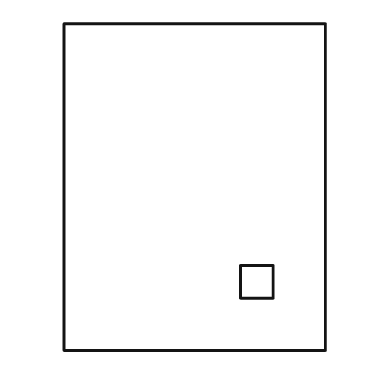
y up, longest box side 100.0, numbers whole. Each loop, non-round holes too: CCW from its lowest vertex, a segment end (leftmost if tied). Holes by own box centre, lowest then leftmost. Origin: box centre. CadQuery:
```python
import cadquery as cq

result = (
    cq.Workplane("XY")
    .moveTo(-40.0, -50.0)
    .lineTo(40.0, -50.0)
    .lineTo(40.0, 50.0)
    .lineTo(-40.0, 50.0)
    .close()
    .moveTo(14.0, -34.0)
    .lineTo(24.0, -34.0)
    .lineTo(24.0, -24.0)
    .lineTo(14.0, -24.0)
    .close()
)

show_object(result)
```